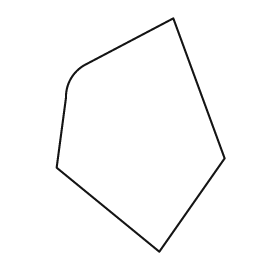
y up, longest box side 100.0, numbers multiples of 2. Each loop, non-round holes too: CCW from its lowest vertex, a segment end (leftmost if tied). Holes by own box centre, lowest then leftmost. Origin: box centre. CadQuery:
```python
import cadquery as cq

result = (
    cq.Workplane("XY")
    .moveTo(8.0, -50.0)
    .lineTo(36.0, -10.0)
    .lineTo(14.0, 50.0)
    .lineTo(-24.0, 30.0)
    .threePointArc((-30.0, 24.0), (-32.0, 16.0))
    .lineTo(-36.0, -14.0)
    .close()
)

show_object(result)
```